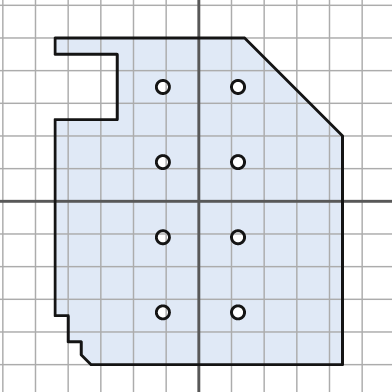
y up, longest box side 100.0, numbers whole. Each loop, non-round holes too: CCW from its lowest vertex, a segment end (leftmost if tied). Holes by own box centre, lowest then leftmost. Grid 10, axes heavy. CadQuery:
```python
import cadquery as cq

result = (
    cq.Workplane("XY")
    .moveTo(-33.0, -50.0)
    .lineTo(44.0, -50.0)
    .lineTo(44.0, 20.0)
    .lineTo(14.0, 50.0)
    .lineTo(-44.0, 50.0)
    .lineTo(-44.0, 45.0)
    .lineTo(-25.0, 45.0)
    .lineTo(-25.0, 25.0)
    .lineTo(-44.0, 25.0)
    .lineTo(-44.0, -35.0)
    .lineTo(-40.0, -35.0)
    .lineTo(-40.0, -43.0)
    .lineTo(-36.0, -43.0)
    .lineTo(-36.0, -47.0)
    .close()
    .moveTo(-11.0, -34.0)
    .circle(2.0)
    .moveTo(12.0, -34.0)
    .circle(2.0)
    .moveTo(-11.0, -11.0)
    .circle(2.0)
    .moveTo(12.0, -11.0)
    .circle(2.0)
    .moveTo(-11.0, 12.0)
    .circle(2.0)
    .moveTo(12.0, 12.0)
    .circle(2.0)
    .moveTo(-11.0, 35.0)
    .circle(2.0)
    .moveTo(12.0, 35.0)
    .circle(2.0)
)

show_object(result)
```